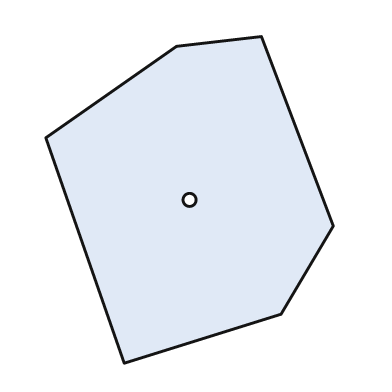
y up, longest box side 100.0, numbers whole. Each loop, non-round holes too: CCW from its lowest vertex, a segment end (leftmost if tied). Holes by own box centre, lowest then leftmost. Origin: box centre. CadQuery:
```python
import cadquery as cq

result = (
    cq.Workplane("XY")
    .moveTo(-20.0, -50.0)
    .lineTo(28.0, -35.0)
    .lineTo(44.0, -8.0)
    .lineTo(22.0, 50.0)
    .lineTo(-4.0, 47.0)
    .lineTo(-44.0, 19.0)
    .close()
    .moveTo(0.0, 0.0)
    .circle(2.0)
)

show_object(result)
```